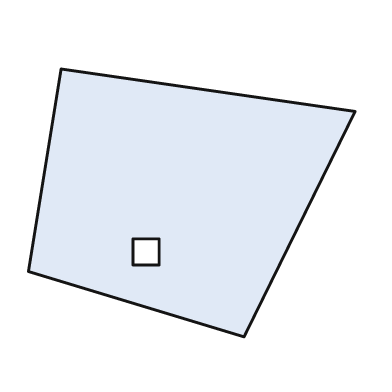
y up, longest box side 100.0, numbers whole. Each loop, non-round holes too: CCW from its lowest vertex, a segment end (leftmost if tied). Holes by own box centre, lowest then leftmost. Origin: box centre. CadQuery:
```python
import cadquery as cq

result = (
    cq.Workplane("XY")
    .moveTo(16.0, -41.0)
    .lineTo(50.0, 28.0)
    .lineTo(-40.0, 41.0)
    .lineTo(-50.0, -21.0)
    .close()
    .moveTo(-18.0, -19.0)
    .lineTo(-10.0, -19.0)
    .lineTo(-10.0, -11.0)
    .lineTo(-18.0, -11.0)
    .close()
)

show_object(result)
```